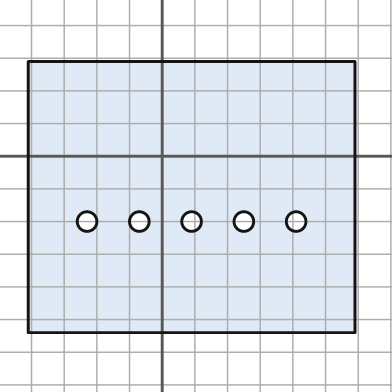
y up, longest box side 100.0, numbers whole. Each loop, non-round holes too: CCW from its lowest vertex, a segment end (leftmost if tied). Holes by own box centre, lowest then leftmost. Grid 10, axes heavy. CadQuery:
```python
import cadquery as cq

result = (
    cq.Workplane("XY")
    .moveTo(-41.0, -54.0)
    .lineTo(59.0, -54.0)
    .lineTo(59.0, 29.0)
    .lineTo(-41.0, 29.0)
    .close()
    .moveTo(-23.0, -20.0)
    .circle(3.0)
    .moveTo(-7.0, -20.0)
    .circle(3.0)
    .moveTo(9.0, -20.0)
    .circle(3.0)
    .moveTo(25.0, -20.0)
    .circle(3.0)
    .moveTo(41.0, -20.0)
    .circle(3.0)
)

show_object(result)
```